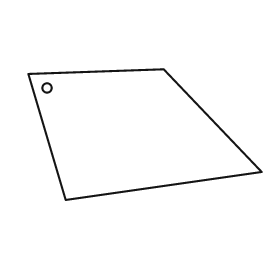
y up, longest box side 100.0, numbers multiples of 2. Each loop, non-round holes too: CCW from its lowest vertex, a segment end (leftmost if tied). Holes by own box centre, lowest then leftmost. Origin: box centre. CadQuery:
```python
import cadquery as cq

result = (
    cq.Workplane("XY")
    .moveTo(-34.0, -28.0)
    .lineTo(50.0, -16.0)
    .lineTo(8.0, 28.0)
    .lineTo(-50.0, 26.0)
    .close()
    .moveTo(-42.0, 20.0)
    .circle(2.0)
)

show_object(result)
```